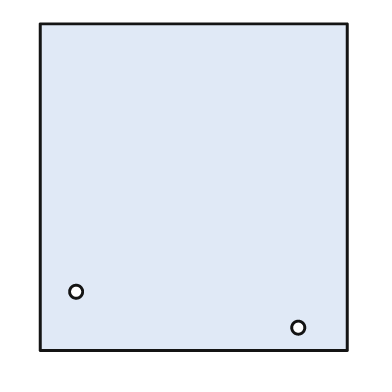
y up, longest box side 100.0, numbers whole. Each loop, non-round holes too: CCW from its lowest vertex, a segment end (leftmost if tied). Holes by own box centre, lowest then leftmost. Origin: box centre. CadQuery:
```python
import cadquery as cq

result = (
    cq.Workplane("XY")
    .moveTo(-47.0, -50.0)
    .lineTo(47.0, -50.0)
    .lineTo(47.0, 50.0)
    .lineTo(-47.0, 50.0)
    .close()
    .moveTo(32.0, -43.0)
    .circle(2.0)
    .moveTo(-36.0, -32.0)
    .circle(2.0)
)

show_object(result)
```